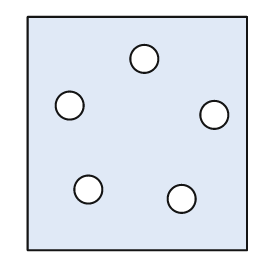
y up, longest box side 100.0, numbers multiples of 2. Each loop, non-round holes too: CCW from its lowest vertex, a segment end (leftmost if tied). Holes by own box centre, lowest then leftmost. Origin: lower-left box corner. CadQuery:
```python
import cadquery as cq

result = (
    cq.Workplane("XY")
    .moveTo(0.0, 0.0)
    .lineTo(94.0, 0.0)
    .lineTo(94.0, 100.0)
    .lineTo(0.0, 100.0)
    .close()
    .moveTo(66.0, 22.0)
    .circle(6.0)
    .moveTo(26.0, 26.0)
    .circle(6.0)
    .moveTo(80.0, 58.0)
    .circle(6.0)
    .moveTo(18.0, 62.0)
    .circle(6.0)
    .moveTo(50.0, 82.0)
    .circle(6.0)
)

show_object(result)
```